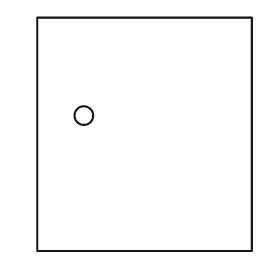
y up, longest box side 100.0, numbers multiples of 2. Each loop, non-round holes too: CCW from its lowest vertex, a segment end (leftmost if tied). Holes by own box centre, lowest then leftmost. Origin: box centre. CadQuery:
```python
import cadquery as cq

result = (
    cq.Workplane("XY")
    .moveTo(-46.0, -50.0)
    .lineTo(46.0, -50.0)
    .lineTo(46.0, 50.0)
    .lineTo(-46.0, 50.0)
    .close()
    .moveTo(-26.0, 8.0)
    .circle(4.0)
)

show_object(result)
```